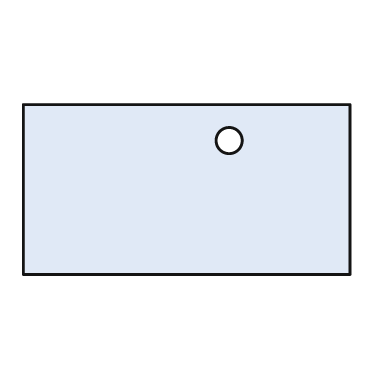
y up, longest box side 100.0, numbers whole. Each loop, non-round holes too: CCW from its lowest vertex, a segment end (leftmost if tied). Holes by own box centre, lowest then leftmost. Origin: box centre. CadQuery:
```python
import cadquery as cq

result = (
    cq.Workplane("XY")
    .moveTo(-50.0, -26.0)
    .lineTo(50.0, -26.0)
    .lineTo(50.0, 26.0)
    .lineTo(-50.0, 26.0)
    .close()
    .moveTo(13.0, 15.0)
    .circle(4.0)
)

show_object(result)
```